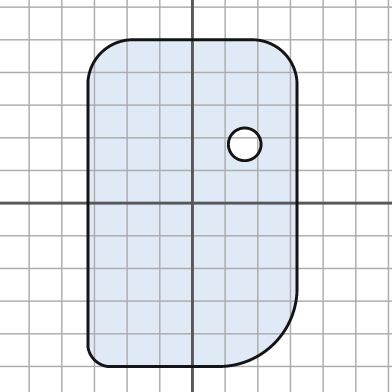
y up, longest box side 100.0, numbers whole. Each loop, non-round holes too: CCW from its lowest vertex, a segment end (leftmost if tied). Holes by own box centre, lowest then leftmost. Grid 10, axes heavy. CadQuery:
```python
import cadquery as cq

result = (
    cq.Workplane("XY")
    .moveTo(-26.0, -50.0)
    .lineTo(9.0, -50.0)
    .threePointArc((25.0, -43.0), (32.0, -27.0))
    .lineTo(32.0, 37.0)
    .threePointArc((28.0, 46.0), (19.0, 50.0))
    .lineTo(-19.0, 50.0)
    .threePointArc((-28.0, 46.0), (-32.0, 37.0))
    .lineTo(-32.0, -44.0)
    .threePointArc((-30.0, -48.0), (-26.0, -50.0))
    .close()
    .moveTo(16.0, 18.0)
    .circle(5.0)
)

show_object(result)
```